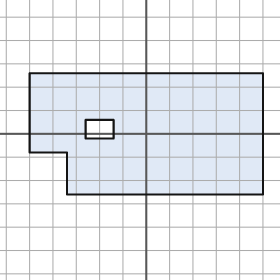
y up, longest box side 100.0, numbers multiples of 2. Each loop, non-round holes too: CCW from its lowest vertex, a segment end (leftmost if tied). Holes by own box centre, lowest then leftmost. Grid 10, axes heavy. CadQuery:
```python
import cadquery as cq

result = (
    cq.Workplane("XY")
    .moveTo(-34.0, -26.0)
    .lineTo(50.0, -26.0)
    .lineTo(50.0, 26.0)
    .lineTo(-50.0, 26.0)
    .lineTo(-50.0, -8.0)
    .lineTo(-34.0, -8.0)
    .close()
    .moveTo(-26.0, -2.0)
    .lineTo(-14.0, -2.0)
    .lineTo(-14.0, 6.0)
    .lineTo(-26.0, 6.0)
    .close()
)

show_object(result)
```